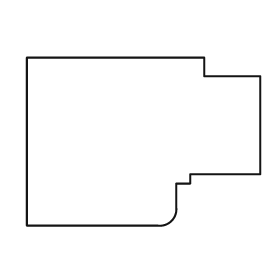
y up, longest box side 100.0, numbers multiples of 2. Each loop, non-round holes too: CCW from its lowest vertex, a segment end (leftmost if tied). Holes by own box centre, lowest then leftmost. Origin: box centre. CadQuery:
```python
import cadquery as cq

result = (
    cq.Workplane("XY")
    .moveTo(-50.0, -36.0)
    .lineTo(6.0, -36.0)
    .threePointArc((12.0, -34.0), (14.0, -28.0))
    .lineTo(14.0, -18.0)
    .lineTo(20.0, -18.0)
    .lineTo(20.0, -14.0)
    .lineTo(50.0, -14.0)
    .lineTo(50.0, 28.0)
    .lineTo(26.0, 28.0)
    .lineTo(26.0, 36.0)
    .lineTo(-50.0, 36.0)
    .close()
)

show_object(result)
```